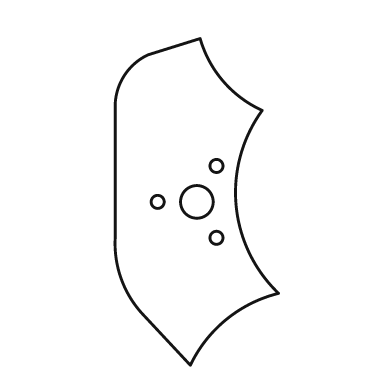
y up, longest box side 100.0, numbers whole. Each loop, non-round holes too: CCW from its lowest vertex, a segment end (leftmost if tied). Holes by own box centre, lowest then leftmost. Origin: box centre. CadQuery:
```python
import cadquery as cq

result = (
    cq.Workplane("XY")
    .moveTo(-2.0, -50.0)
    .threePointArc((9.0, -36.0), (25.0, -28.0))
    .threePointArc((12.0, -1.0), (20.0, 28.0))
    .threePointArc((8.0, 37.0), (1.0, 50.0))
    .lineTo(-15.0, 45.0)
    .threePointArc((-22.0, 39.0), (-25.0, 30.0))
    .lineTo(-25.0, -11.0)
    .threePointArc((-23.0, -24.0), (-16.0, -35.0))
    .close()
    .moveTo(6.0, -11.0)
    .circle(2.0)
    .moveTo(-12.0, 0.0)
    .circle(2.0)
    .moveTo(0.0, 0.0)
    .circle(5.0)
    .moveTo(6.0, 11.0)
    .circle(2.0)
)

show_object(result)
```